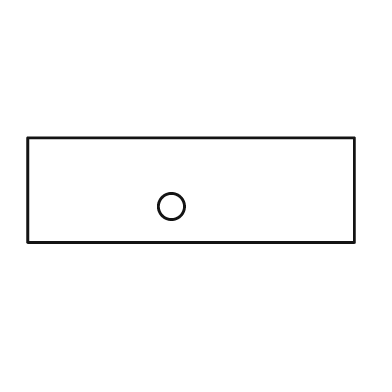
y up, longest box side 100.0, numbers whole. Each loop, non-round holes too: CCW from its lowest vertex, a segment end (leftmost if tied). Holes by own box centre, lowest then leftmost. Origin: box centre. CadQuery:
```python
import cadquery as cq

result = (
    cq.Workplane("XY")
    .moveTo(-50.0, -16.0)
    .lineTo(50.0, -16.0)
    .lineTo(50.0, 16.0)
    .lineTo(-50.0, 16.0)
    .close()
    .moveTo(-6.0, -5.0)
    .circle(4.0)
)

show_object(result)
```